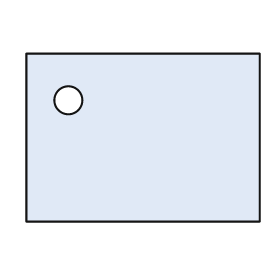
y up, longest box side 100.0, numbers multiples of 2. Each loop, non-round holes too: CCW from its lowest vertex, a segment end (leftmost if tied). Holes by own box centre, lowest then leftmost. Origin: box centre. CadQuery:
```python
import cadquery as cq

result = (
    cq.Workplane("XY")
    .moveTo(-50.0, -36.0)
    .lineTo(50.0, -36.0)
    .lineTo(50.0, 36.0)
    .lineTo(-50.0, 36.0)
    .close()
    .moveTo(-32.0, 16.0)
    .circle(6.0)
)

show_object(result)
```